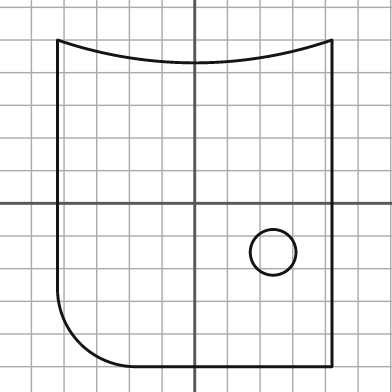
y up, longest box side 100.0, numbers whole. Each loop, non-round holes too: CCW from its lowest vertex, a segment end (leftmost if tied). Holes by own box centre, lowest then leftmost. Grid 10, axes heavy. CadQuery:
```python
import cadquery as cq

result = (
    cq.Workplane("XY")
    .moveTo(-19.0, -50.0)
    .lineTo(42.0, -50.0)
    .lineTo(42.0, 50.0)
    .threePointArc((0.0, 43.0), (-42.0, 50.0))
    .lineTo(-42.0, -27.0)
    .threePointArc((-35.0, -43.0), (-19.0, -50.0))
    .close()
    .moveTo(24.0, -15.0)
    .circle(7.0)
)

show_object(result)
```